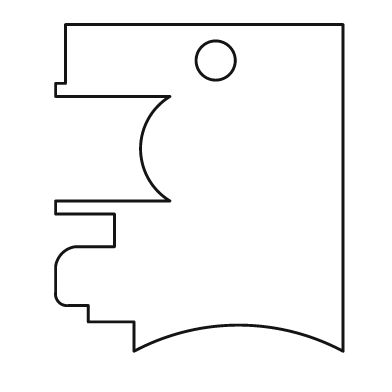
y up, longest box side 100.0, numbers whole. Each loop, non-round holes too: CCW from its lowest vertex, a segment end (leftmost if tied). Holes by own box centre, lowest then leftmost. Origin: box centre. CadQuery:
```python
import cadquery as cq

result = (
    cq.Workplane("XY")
    .moveTo(-20.0, -50.0)
    .threePointArc((12.0, -42.0), (44.0, -50.0))
    .lineTo(44.0, 50.0)
    .lineTo(-41.0, 50.0)
    .lineTo(-41.0, 32.0)
    .lineTo(-44.0, 32.0)
    .lineTo(-44.0, 28.0)
    .lineTo(-9.0, 28.0)
    .threePointArc((-18.0, 12.0), (-9.0, -4.0))
    .lineTo(-44.0, -4.0)
    .lineTo(-44.0, -8.0)
    .lineTo(-26.0, -8.0)
    .lineTo(-26.0, -18.0)
    .lineTo(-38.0, -18.0)
    .threePointArc((-42.0, -20.0), (-44.0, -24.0))
    .lineTo(-44.0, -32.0)
    .threePointArc((-43.0, -35.0), (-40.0, -36.0))
    .lineTo(-34.0, -36.0)
    .lineTo(-34.0, -41.0)
    .lineTo(-20.0, -41.0)
    .close()
    .moveTo(5.0, 39.0)
    .circle(6.0)
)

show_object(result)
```